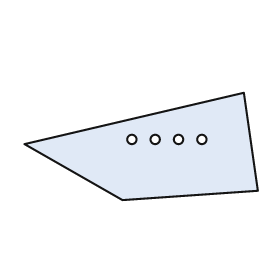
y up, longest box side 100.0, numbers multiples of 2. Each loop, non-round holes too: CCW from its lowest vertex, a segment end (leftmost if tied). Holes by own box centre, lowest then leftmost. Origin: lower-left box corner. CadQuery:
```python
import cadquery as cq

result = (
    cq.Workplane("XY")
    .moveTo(42.0, 0.0)
    .lineTo(100.0, 4.0)
    .lineTo(94.0, 46.0)
    .lineTo(0.0, 24.0)
    .close()
    .moveTo(46.0, 26.0)
    .circle(2.0)
    .moveTo(56.0, 26.0)
    .circle(2.0)
    .moveTo(66.0, 26.0)
    .circle(2.0)
    .moveTo(76.0, 26.0)
    .circle(2.0)
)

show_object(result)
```